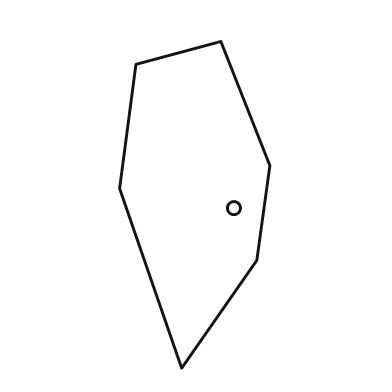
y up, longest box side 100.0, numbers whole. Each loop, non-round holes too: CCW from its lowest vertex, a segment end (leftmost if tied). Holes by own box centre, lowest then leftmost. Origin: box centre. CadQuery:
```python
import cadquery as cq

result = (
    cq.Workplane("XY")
    .moveTo(-4.0, -50.0)
    .lineTo(19.0, -17.0)
    .lineTo(23.0, 12.0)
    .lineTo(8.0, 50.0)
    .lineTo(-18.0, 43.0)
    .lineTo(-23.0, 5.0)
    .close()
    .moveTo(12.0, -1.0)
    .circle(2.0)
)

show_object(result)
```